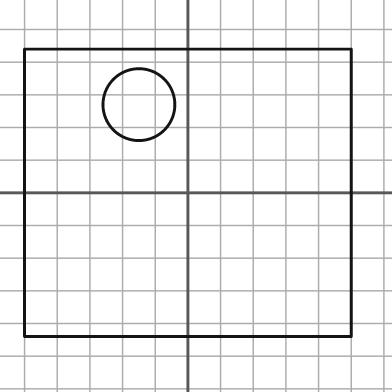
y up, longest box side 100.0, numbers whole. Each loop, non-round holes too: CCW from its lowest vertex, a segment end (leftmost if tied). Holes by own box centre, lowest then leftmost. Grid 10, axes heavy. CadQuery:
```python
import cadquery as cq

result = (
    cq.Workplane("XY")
    .moveTo(-50.0, -44.0)
    .lineTo(50.0, -44.0)
    .lineTo(50.0, 44.0)
    .lineTo(-50.0, 44.0)
    .close()
    .moveTo(-15.0, 27.0)
    .circle(11.0)
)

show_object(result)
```